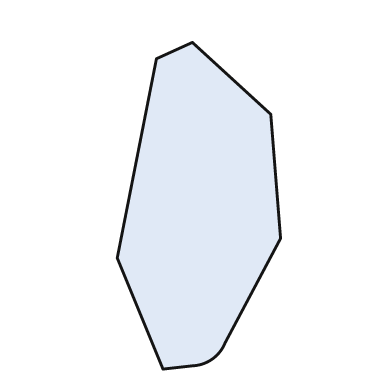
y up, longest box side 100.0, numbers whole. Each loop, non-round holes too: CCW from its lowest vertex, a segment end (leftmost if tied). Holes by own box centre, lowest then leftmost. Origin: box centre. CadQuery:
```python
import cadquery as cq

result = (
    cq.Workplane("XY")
    .moveTo(-11.0, -50.0)
    .lineTo(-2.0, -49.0)
    .threePointArc((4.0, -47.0), (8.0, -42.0))
    .lineTo(25.0, -10.0)
    .lineTo(22.0, 28.0)
    .lineTo(-2.0, 50.0)
    .lineTo(-13.0, 45.0)
    .lineTo(-25.0, -16.0)
    .close()
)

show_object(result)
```